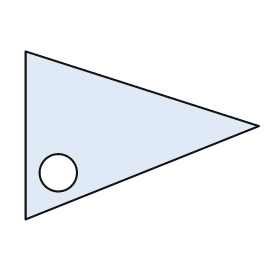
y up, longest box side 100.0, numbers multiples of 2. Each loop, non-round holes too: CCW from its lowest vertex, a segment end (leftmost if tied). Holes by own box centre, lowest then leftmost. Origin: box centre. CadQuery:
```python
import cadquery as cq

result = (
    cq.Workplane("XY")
    .moveTo(-50.0, -36.0)
    .lineTo(50.0, 4.0)
    .lineTo(-50.0, 36.0)
    .close()
    .moveTo(-36.0, -16.0)
    .circle(8.0)
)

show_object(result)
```